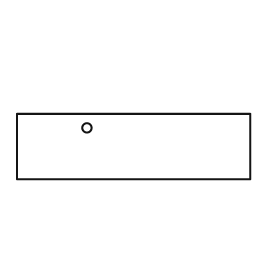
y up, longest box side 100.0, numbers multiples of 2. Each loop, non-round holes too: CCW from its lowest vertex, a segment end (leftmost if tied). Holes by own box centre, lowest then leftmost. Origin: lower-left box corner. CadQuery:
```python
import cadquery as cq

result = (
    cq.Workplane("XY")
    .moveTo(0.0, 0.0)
    .lineTo(100.0, 0.0)
    .lineTo(100.0, 28.0)
    .lineTo(0.0, 28.0)
    .close()
    .moveTo(30.0, 22.0)
    .circle(2.0)
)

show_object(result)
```